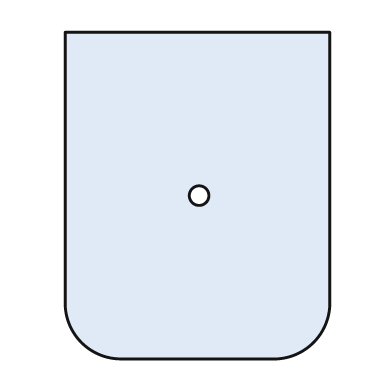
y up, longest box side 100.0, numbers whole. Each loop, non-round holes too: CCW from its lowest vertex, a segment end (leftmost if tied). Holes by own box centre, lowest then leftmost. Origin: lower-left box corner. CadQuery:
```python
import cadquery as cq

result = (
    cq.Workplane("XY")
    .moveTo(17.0, 0.0)
    .lineTo(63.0, 0.0)
    .threePointArc((76.0, 5.0), (81.0, 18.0))
    .lineTo(81.0, 100.0)
    .lineTo(0.0, 100.0)
    .lineTo(0.0, 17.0)
    .threePointArc((5.0, 5.0), (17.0, 0.0))
    .close()
    .moveTo(41.0, 50.0)
    .circle(3.0)
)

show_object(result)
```